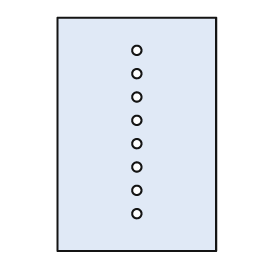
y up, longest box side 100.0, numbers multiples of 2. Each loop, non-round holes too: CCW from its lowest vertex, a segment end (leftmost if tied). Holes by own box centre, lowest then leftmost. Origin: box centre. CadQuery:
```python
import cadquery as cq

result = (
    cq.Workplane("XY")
    .moveTo(-34.0, -50.0)
    .lineTo(34.0, -50.0)
    .lineTo(34.0, 50.0)
    .lineTo(-34.0, 50.0)
    .close()
    .moveTo(0.0, -34.0)
    .circle(2.0)
    .moveTo(0.0, -24.0)
    .circle(2.0)
    .moveTo(0.0, -14.0)
    .circle(2.0)
    .moveTo(0.0, -4.0)
    .circle(2.0)
    .moveTo(0.0, 6.0)
    .circle(2.0)
    .moveTo(0.0, 16.0)
    .circle(2.0)
    .moveTo(0.0, 26.0)
    .circle(2.0)
    .moveTo(0.0, 36.0)
    .circle(2.0)
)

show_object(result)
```